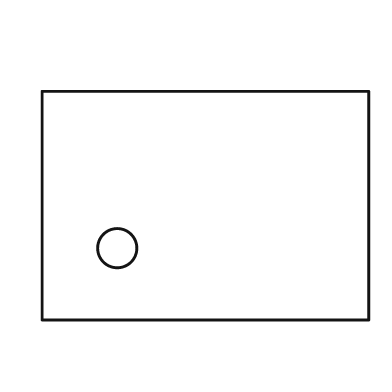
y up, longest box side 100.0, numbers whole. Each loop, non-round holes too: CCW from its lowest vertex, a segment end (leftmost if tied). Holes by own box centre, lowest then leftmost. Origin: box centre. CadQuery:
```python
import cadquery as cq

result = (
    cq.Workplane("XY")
    .moveTo(-50.0, -35.0)
    .lineTo(50.0, -35.0)
    .lineTo(50.0, 35.0)
    .lineTo(-50.0, 35.0)
    .close()
    .moveTo(-27.0, -13.0)
    .circle(6.0)
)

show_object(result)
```